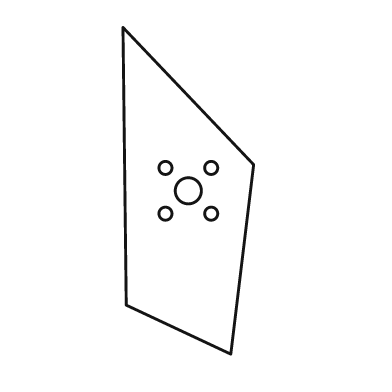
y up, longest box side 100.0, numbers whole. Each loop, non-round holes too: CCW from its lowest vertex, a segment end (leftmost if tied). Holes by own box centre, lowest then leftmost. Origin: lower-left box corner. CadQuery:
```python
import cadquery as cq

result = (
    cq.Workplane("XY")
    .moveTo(33.0, 0.0)
    .lineTo(40.0, 58.0)
    .lineTo(0.0, 100.0)
    .lineTo(1.0, 15.0)
    .close()
    .moveTo(13.0, 43.0)
    .circle(2.0)
    .moveTo(27.0, 43.0)
    .circle(2.0)
    .moveTo(20.0, 50.0)
    .circle(4.0)
    .moveTo(13.0, 57.0)
    .circle(2.0)
    .moveTo(27.0, 57.0)
    .circle(2.0)
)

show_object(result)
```